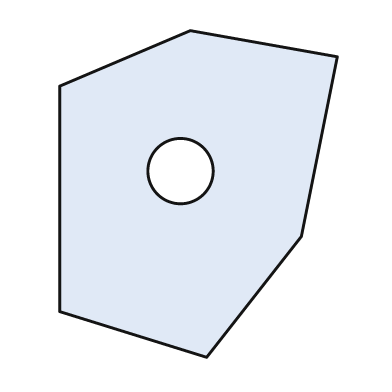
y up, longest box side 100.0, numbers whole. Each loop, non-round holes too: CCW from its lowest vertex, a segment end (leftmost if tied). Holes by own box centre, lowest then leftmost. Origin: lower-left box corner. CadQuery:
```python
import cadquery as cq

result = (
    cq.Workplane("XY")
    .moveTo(45.0, 0.0)
    .lineTo(74.0, 37.0)
    .lineTo(85.0, 92.0)
    .lineTo(40.0, 100.0)
    .lineTo(0.0, 83.0)
    .lineTo(0.0, 14.0)
    .close()
    .moveTo(37.0, 57.0)
    .circle(10.0)
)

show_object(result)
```